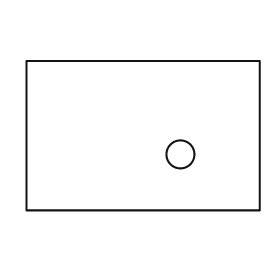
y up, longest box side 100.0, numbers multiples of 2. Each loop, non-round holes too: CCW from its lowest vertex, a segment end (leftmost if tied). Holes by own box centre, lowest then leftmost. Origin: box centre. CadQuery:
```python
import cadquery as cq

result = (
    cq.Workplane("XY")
    .moveTo(-50.0, -32.0)
    .lineTo(50.0, -32.0)
    .lineTo(50.0, 32.0)
    .lineTo(-50.0, 32.0)
    .close()
    .moveTo(16.0, -8.0)
    .circle(6.0)
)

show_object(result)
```